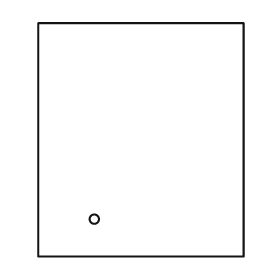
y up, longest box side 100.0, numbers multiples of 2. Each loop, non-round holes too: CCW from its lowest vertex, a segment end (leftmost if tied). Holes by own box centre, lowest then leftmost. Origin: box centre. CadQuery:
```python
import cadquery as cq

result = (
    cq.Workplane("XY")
    .moveTo(-44.0, -50.0)
    .lineTo(44.0, -50.0)
    .lineTo(44.0, 50.0)
    .lineTo(-44.0, 50.0)
    .close()
    .moveTo(-20.0, -34.0)
    .circle(2.0)
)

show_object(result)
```